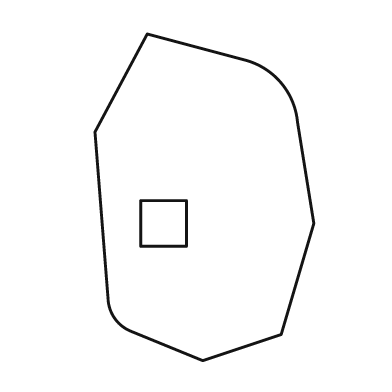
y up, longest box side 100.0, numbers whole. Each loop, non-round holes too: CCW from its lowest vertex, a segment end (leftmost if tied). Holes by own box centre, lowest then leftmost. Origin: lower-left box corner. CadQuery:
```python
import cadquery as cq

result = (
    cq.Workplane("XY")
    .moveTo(33.0, 0.0)
    .lineTo(57.0, 8.0)
    .lineTo(67.0, 42.0)
    .lineTo(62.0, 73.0)
    .threePointArc((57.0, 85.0), (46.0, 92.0))
    .lineTo(16.0, 100.0)
    .lineTo(0.0, 70.0)
    .lineTo(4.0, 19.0)
    .threePointArc((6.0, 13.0), (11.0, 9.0))
    .close()
    .moveTo(14.0, 35.0)
    .lineTo(28.0, 35.0)
    .lineTo(28.0, 49.0)
    .lineTo(14.0, 49.0)
    .close()
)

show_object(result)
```